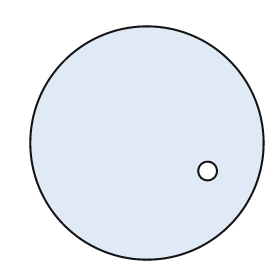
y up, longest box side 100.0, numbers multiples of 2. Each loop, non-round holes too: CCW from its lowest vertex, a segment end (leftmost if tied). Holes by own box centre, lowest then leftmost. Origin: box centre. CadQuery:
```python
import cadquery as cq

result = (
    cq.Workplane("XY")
    .moveTo(0.0, 0.0)
    .circle(50.0)
    .moveTo(26.0, -12.0)
    .circle(4.0)
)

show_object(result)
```